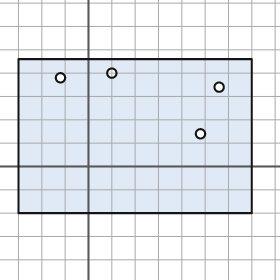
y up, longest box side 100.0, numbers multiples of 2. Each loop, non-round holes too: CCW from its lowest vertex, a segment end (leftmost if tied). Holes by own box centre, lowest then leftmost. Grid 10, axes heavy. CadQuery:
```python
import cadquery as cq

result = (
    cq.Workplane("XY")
    .moveTo(-30.0, -20.0)
    .lineTo(70.0, -20.0)
    .lineTo(70.0, 46.0)
    .lineTo(-30.0, 46.0)
    .close()
    .moveTo(48.0, 14.0)
    .circle(2.0)
    .moveTo(56.0, 34.0)
    .circle(2.0)
    .moveTo(-12.0, 38.0)
    .circle(2.0)
    .moveTo(10.0, 40.0)
    .circle(2.0)
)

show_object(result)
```